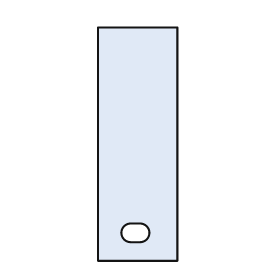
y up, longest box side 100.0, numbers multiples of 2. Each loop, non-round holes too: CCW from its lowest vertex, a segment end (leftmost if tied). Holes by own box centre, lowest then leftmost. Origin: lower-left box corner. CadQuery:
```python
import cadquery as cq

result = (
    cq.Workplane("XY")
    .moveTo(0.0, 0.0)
    .lineTo(34.0, 0.0)
    .lineTo(34.0, 100.0)
    .lineTo(0.0, 100.0)
    .close()
    .moveTo(14.0, 8.0)
    .lineTo(18.0, 8.0)
    .threePointArc((22.0, 12.0), (18.0, 16.0))
    .lineTo(14.0, 16.0)
    .threePointArc((10.0, 12.0), (14.0, 8.0))
    .close()
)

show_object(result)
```